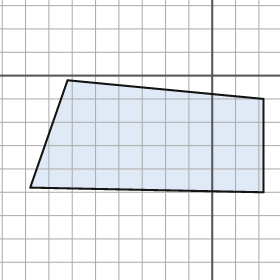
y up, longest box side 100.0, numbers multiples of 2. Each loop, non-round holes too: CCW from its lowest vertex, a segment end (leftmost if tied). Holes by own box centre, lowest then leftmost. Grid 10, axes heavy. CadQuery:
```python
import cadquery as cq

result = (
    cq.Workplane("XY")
    .moveTo(22.0, -50.0)
    .lineTo(22.0, -10.0)
    .lineTo(-62.0, -2.0)
    .lineTo(-78.0, -48.0)
    .close()
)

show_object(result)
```